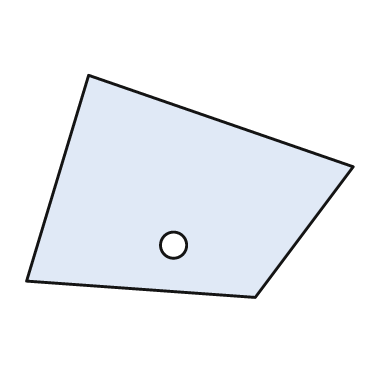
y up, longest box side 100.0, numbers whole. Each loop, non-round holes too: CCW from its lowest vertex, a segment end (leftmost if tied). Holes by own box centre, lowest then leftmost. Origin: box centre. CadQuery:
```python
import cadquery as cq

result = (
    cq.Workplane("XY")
    .moveTo(20.0, -34.0)
    .lineTo(50.0, 6.0)
    .lineTo(-31.0, 34.0)
    .lineTo(-50.0, -29.0)
    .close()
    .moveTo(-5.0, -18.0)
    .circle(4.0)
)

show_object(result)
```